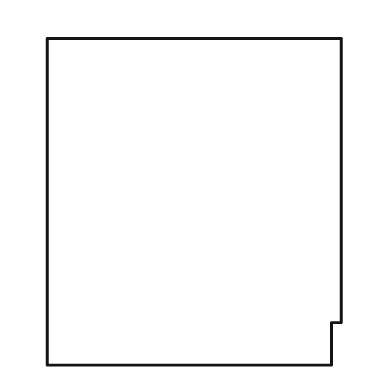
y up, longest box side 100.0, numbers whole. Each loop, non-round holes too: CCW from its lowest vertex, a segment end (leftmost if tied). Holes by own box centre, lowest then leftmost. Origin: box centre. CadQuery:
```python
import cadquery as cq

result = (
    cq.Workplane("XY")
    .moveTo(-45.0, -50.0)
    .lineTo(42.0, -50.0)
    .lineTo(42.0, -37.0)
    .lineTo(45.0, -37.0)
    .lineTo(45.0, 50.0)
    .lineTo(-45.0, 50.0)
    .close()
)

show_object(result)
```